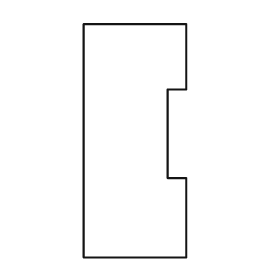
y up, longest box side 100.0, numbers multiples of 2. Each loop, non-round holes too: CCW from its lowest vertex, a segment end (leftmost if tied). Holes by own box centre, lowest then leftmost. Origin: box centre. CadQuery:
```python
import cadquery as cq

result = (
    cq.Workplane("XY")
    .moveTo(-22.0, -50.0)
    .lineTo(22.0, -50.0)
    .lineTo(22.0, -16.0)
    .lineTo(14.0, -16.0)
    .lineTo(14.0, 22.0)
    .lineTo(22.0, 22.0)
    .lineTo(22.0, 50.0)
    .lineTo(-22.0, 50.0)
    .close()
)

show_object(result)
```